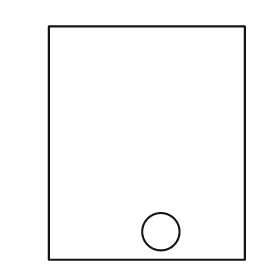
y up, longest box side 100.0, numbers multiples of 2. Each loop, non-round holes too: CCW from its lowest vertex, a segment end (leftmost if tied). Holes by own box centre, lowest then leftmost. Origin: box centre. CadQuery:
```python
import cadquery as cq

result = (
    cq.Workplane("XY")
    .moveTo(-42.0, -50.0)
    .lineTo(42.0, -50.0)
    .lineTo(42.0, 50.0)
    .lineTo(-42.0, 50.0)
    .close()
    .moveTo(6.0, -38.0)
    .circle(8.0)
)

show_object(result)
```